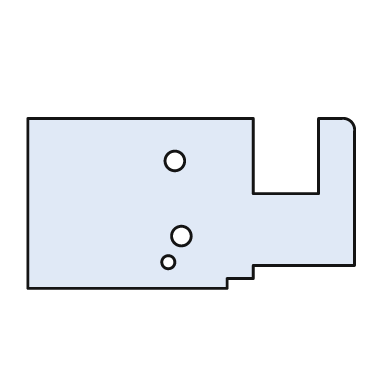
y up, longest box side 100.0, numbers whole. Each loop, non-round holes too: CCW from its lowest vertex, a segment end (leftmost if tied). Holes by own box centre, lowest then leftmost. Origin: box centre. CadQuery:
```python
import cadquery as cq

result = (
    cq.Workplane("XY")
    .moveTo(-50.0, -26.0)
    .lineTo(11.0, -26.0)
    .lineTo(11.0, -23.0)
    .lineTo(19.0, -23.0)
    .lineTo(19.0, -19.0)
    .lineTo(50.0, -19.0)
    .lineTo(50.0, 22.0)
    .threePointArc((49.0, 25.0), (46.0, 26.0))
    .lineTo(39.0, 26.0)
    .lineTo(39.0, 3.0)
    .lineTo(19.0, 3.0)
    .lineTo(19.0, 26.0)
    .lineTo(-50.0, 26.0)
    .close()
    .moveTo(-7.0, -18.0)
    .circle(2.0)
    .moveTo(-3.0, -10.0)
    .circle(3.0)
    .moveTo(-5.0, 13.0)
    .circle(3.0)
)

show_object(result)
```